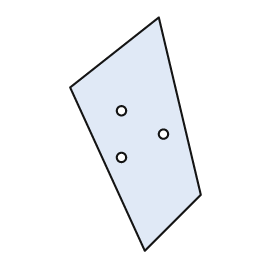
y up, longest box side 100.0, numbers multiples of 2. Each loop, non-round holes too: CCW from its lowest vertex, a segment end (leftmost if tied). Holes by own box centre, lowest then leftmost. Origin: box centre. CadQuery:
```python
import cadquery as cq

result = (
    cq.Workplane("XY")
    .moveTo(4.0, -50.0)
    .lineTo(28.0, -26.0)
    .lineTo(10.0, 50.0)
    .lineTo(-28.0, 20.0)
    .close()
    .moveTo(-6.0, -10.0)
    .circle(2.0)
    .moveTo(12.0, 0.0)
    .circle(2.0)
    .moveTo(-6.0, 10.0)
    .circle(2.0)
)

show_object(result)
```